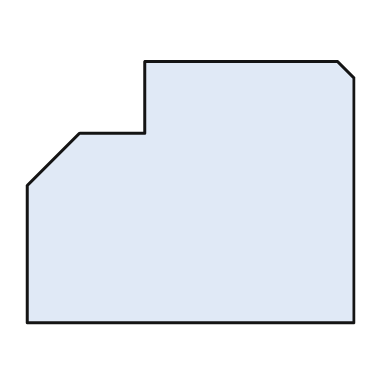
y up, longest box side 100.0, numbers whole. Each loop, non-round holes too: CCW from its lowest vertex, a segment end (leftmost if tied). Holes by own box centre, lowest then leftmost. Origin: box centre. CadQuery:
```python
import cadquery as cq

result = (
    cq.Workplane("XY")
    .moveTo(-50.0, -40.0)
    .lineTo(50.0, -40.0)
    .lineTo(50.0, 35.0)
    .lineTo(45.0, 40.0)
    .lineTo(-14.0, 40.0)
    .lineTo(-14.0, 18.0)
    .lineTo(-34.0, 18.0)
    .lineTo(-50.0, 2.0)
    .close()
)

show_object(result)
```